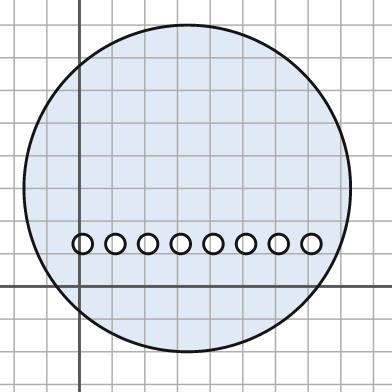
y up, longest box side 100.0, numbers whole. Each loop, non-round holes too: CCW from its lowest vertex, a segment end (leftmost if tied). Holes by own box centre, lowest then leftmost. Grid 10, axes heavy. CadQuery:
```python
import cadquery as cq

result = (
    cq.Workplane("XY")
    .moveTo(33.0, 30.0)
    .circle(50.0)
    .moveTo(1.0, 13.0)
    .circle(3.0)
    .moveTo(11.0, 13.0)
    .circle(3.0)
    .moveTo(21.0, 13.0)
    .circle(3.0)
    .moveTo(31.0, 13.0)
    .circle(3.0)
    .moveTo(41.0, 13.0)
    .circle(3.0)
    .moveTo(51.0, 13.0)
    .circle(3.0)
    .moveTo(61.0, 13.0)
    .circle(3.0)
    .moveTo(71.0, 13.0)
    .circle(3.0)
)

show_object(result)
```